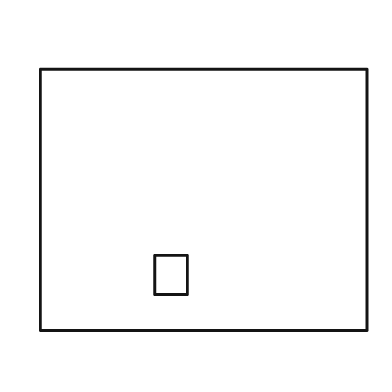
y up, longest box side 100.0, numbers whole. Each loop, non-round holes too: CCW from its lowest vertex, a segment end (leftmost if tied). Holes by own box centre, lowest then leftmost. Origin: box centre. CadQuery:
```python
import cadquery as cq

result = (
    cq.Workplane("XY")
    .moveTo(-50.0, -40.0)
    .lineTo(50.0, -40.0)
    .lineTo(50.0, 40.0)
    .lineTo(-50.0, 40.0)
    .close()
    .moveTo(-15.0, -29.0)
    .lineTo(-5.0, -29.0)
    .lineTo(-5.0, -17.0)
    .lineTo(-15.0, -17.0)
    .close()
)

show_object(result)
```